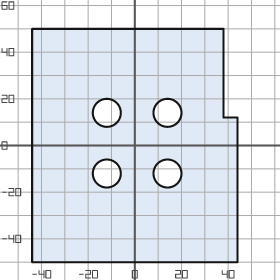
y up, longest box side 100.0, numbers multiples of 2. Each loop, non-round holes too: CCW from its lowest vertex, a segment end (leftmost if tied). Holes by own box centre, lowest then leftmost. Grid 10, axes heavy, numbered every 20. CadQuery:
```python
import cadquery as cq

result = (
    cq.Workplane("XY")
    .moveTo(-44.0, -50.0)
    .lineTo(44.0, -50.0)
    .lineTo(44.0, 12.0)
    .lineTo(38.0, 12.0)
    .lineTo(38.0, 50.0)
    .lineTo(-44.0, 50.0)
    .close()
    .moveTo(-12.0, -12.0)
    .circle(6.0)
    .moveTo(14.0, -12.0)
    .circle(6.0)
    .moveTo(-12.0, 14.0)
    .circle(6.0)
    .moveTo(14.0, 14.0)
    .circle(6.0)
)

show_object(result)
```